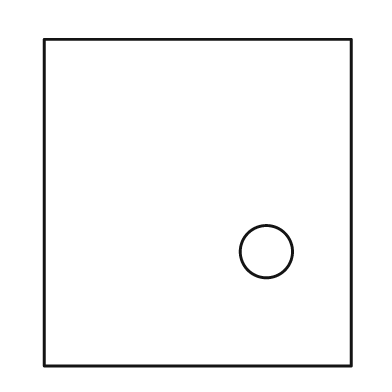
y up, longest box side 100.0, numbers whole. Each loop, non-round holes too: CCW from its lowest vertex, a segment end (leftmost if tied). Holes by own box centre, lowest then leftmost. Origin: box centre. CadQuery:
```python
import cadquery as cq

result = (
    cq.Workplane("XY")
    .moveTo(-47.0, -50.0)
    .lineTo(47.0, -50.0)
    .lineTo(47.0, 50.0)
    .lineTo(-47.0, 50.0)
    .close()
    .moveTo(21.0, -15.0)
    .circle(8.0)
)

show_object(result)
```